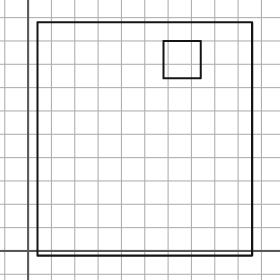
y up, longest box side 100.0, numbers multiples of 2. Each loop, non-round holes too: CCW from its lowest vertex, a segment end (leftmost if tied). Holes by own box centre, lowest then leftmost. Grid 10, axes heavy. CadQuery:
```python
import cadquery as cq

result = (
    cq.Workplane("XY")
    .moveTo(4.0, -2.0)
    .lineTo(96.0, -2.0)
    .lineTo(96.0, 98.0)
    .lineTo(4.0, 98.0)
    .close()
    .moveTo(58.0, 74.0)
    .lineTo(74.0, 74.0)
    .lineTo(74.0, 90.0)
    .lineTo(58.0, 90.0)
    .close()
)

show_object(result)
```